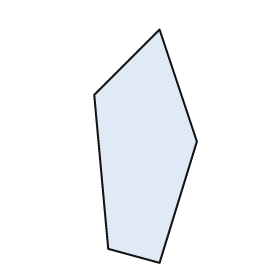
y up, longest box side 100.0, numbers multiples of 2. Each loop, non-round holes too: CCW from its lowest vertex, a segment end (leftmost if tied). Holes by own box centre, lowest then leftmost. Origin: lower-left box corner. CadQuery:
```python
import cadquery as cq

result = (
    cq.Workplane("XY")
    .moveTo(28.0, 0.0)
    .lineTo(44.0, 52.0)
    .lineTo(28.0, 100.0)
    .lineTo(0.0, 72.0)
    .lineTo(6.0, 6.0)
    .close()
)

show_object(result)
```